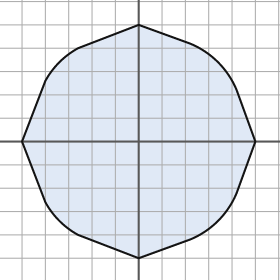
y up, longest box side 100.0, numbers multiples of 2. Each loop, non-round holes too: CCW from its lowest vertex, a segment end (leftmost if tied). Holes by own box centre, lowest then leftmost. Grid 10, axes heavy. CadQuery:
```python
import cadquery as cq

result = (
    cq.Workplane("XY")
    .moveTo(0.0, -50.0)
    .lineTo(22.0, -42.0)
    .threePointArc((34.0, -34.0), (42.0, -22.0))
    .lineTo(50.0, 0.0)
    .lineTo(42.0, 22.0)
    .threePointArc((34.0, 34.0), (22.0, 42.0))
    .lineTo(0.0, 50.0)
    .lineTo(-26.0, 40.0)
    .threePointArc((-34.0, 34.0), (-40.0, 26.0))
    .lineTo(-50.0, 0.0)
    .lineTo(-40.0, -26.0)
    .threePointArc((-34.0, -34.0), (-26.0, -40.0))
    .close()
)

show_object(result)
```